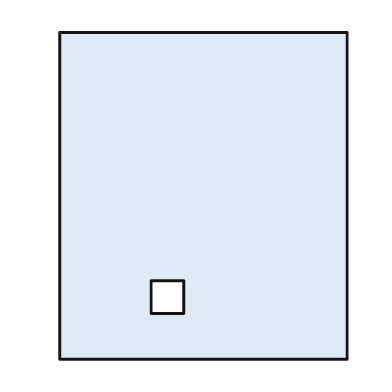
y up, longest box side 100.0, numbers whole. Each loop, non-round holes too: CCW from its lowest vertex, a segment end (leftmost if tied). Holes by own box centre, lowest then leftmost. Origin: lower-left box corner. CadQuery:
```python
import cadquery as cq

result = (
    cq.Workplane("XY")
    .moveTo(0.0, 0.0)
    .lineTo(88.0, 0.0)
    .lineTo(88.0, 100.0)
    .lineTo(0.0, 100.0)
    .close()
    .moveTo(28.0, 14.0)
    .lineTo(38.0, 14.0)
    .lineTo(38.0, 24.0)
    .lineTo(28.0, 24.0)
    .close()
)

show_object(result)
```